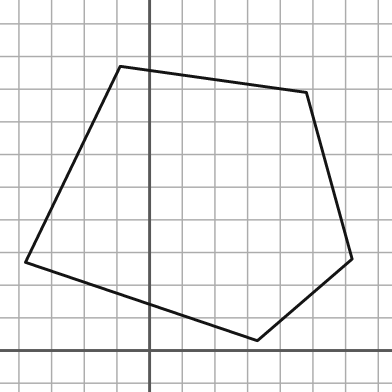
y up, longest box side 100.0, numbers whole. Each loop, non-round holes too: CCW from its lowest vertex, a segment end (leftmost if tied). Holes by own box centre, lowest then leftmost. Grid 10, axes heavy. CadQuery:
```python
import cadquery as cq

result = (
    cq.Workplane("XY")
    .moveTo(33.0, 3.0)
    .lineTo(62.0, 28.0)
    .lineTo(48.0, 79.0)
    .lineTo(-9.0, 87.0)
    .lineTo(-38.0, 27.0)
    .close()
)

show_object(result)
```